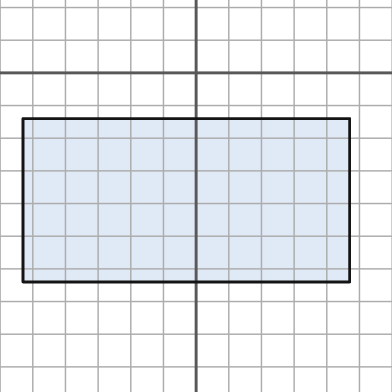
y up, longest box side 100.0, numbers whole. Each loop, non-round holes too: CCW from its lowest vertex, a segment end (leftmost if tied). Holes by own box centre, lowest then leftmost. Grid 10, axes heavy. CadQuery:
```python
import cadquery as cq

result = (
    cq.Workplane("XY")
    .moveTo(-53.0, -64.0)
    .lineTo(47.0, -64.0)
    .lineTo(47.0, -14.0)
    .lineTo(-53.0, -14.0)
    .close()
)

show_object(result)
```